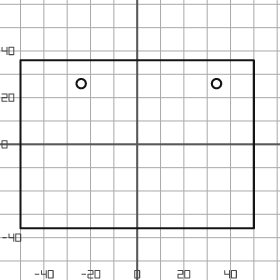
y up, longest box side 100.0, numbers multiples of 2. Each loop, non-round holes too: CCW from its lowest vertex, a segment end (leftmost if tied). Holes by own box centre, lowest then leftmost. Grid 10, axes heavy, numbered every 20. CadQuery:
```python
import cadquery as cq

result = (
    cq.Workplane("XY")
    .moveTo(-50.0, -36.0)
    .lineTo(50.0, -36.0)
    .lineTo(50.0, 36.0)
    .lineTo(-50.0, 36.0)
    .close()
    .moveTo(-24.0, 26.0)
    .circle(2.0)
    .moveTo(34.0, 26.0)
    .circle(2.0)
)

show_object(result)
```